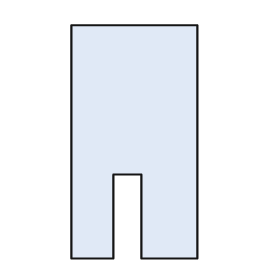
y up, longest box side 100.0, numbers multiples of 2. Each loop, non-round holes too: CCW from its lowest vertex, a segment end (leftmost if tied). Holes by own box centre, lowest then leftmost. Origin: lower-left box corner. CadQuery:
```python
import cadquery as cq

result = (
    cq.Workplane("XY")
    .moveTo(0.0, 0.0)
    .lineTo(18.0, 0.0)
    .lineTo(18.0, 36.0)
    .lineTo(30.0, 36.0)
    .lineTo(30.0, 0.0)
    .lineTo(54.0, 0.0)
    .lineTo(54.0, 100.0)
    .lineTo(0.0, 100.0)
    .close()
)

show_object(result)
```